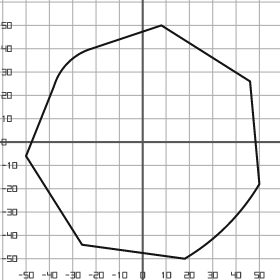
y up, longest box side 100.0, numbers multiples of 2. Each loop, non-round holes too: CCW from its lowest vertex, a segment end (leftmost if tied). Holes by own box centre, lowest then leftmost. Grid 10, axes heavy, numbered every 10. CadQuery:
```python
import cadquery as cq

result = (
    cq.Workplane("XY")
    .moveTo(18.0, -50.0)
    .threePointArc((36.0, -36.0), (50.0, -18.0))
    .lineTo(46.0, 26.0)
    .lineTo(8.0, 50.0)
    .lineTo(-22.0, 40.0)
    .threePointArc((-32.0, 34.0), (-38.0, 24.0))
    .lineTo(-50.0, -6.0)
    .lineTo(-26.0, -44.0)
    .close()
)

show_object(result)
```